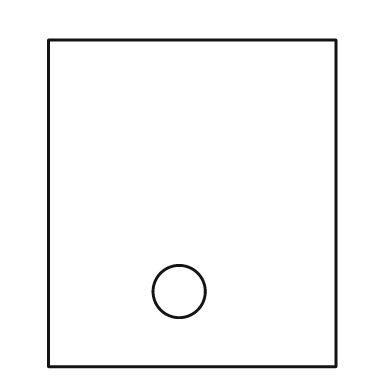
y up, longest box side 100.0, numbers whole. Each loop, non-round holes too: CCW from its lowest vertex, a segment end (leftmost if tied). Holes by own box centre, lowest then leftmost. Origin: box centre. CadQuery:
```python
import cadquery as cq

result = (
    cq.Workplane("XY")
    .moveTo(-44.0, -50.0)
    .lineTo(44.0, -50.0)
    .lineTo(44.0, 50.0)
    .lineTo(-44.0, 50.0)
    .close()
    .moveTo(-4.0, -27.0)
    .circle(8.0)
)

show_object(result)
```